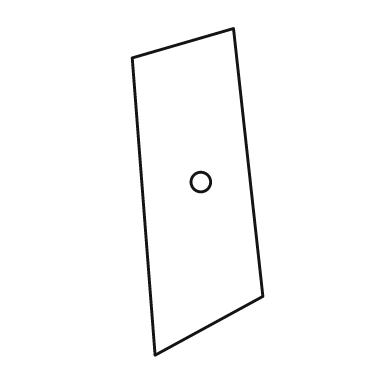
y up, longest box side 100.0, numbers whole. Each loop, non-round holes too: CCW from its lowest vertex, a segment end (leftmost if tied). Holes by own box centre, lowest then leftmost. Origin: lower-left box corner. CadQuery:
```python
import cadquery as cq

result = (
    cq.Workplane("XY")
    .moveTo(7.0, 0.0)
    .lineTo(40.0, 18.0)
    .lineTo(31.0, 100.0)
    .lineTo(0.0, 91.0)
    .close()
    .moveTo(21.0, 53.0)
    .circle(3.0)
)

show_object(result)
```